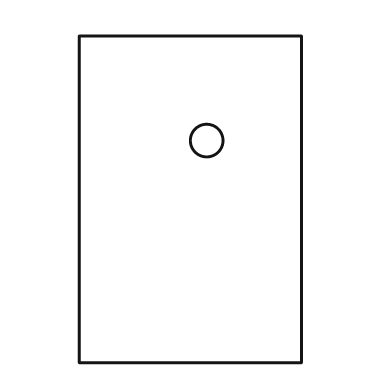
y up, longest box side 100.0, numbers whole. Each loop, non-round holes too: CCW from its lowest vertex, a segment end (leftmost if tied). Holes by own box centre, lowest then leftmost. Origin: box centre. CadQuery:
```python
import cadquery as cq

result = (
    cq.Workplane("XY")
    .moveTo(-34.0, -50.0)
    .lineTo(34.0, -50.0)
    .lineTo(34.0, 50.0)
    .lineTo(-34.0, 50.0)
    .close()
    .moveTo(5.0, 18.0)
    .circle(5.0)
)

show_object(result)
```